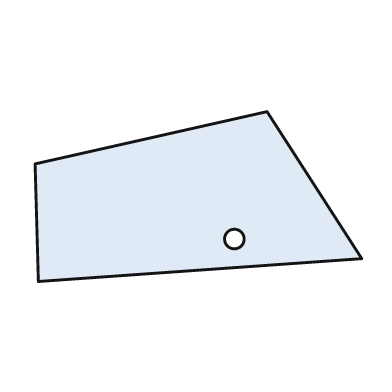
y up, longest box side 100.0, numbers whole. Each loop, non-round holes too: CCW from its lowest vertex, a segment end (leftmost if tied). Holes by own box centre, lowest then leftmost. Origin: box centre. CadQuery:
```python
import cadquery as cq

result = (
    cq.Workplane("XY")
    .moveTo(-49.0, -26.0)
    .lineTo(50.0, -19.0)
    .lineTo(21.0, 26.0)
    .lineTo(-50.0, 10.0)
    .close()
    .moveTo(11.0, -13.0)
    .circle(3.0)
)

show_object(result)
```